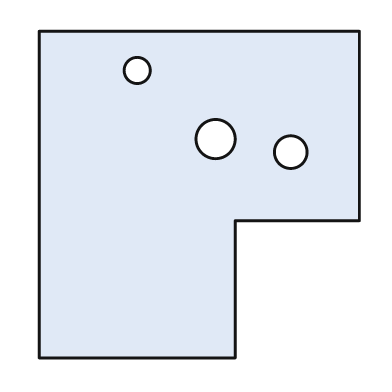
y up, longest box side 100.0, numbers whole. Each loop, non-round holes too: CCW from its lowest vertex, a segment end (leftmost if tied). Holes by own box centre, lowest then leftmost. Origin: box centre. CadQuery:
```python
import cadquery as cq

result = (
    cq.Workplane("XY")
    .moveTo(-49.0, -50.0)
    .lineTo(11.0, -50.0)
    .lineTo(11.0, -8.0)
    .lineTo(49.0, -8.0)
    .lineTo(49.0, 50.0)
    .lineTo(-49.0, 50.0)
    .close()
    .moveTo(28.0, 13.0)
    .circle(5.0)
    .moveTo(5.0, 17.0)
    .circle(6.0)
    .moveTo(-19.0, 38.0)
    .circle(4.0)
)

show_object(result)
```